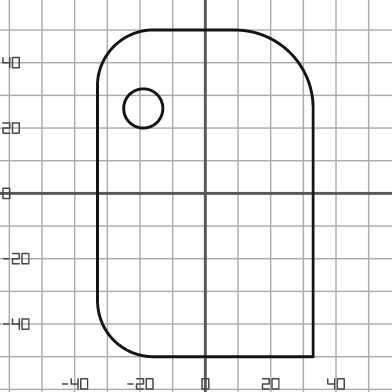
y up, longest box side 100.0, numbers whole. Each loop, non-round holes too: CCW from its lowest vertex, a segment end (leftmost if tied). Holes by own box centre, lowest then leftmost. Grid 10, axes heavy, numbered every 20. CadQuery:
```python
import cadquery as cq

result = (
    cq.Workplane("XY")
    .moveTo(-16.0, -50.0)
    .lineTo(33.0, -50.0)
    .lineTo(33.0, 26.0)
    .threePointArc((26.0, 43.0), (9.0, 50.0))
    .lineTo(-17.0, 50.0)
    .threePointArc((-28.0, 45.0), (-33.0, 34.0))
    .lineTo(-33.0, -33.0)
    .threePointArc((-28.0, -45.0), (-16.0, -50.0))
    .close()
    .moveTo(-19.0, 26.0)
    .circle(6.0)
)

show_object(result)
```